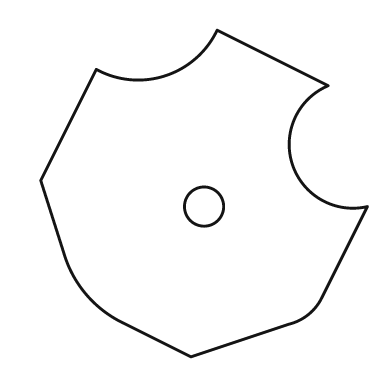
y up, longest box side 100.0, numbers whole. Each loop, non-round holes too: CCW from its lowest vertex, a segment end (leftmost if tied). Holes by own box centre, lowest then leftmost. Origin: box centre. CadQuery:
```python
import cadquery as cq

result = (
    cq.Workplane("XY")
    .moveTo(-4.0, -50.0)
    .lineTo(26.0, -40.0)
    .threePointArc((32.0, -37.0), (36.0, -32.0))
    .lineTo(50.0, -4.0)
    .threePointArc((27.0, 9.0), (38.0, 33.0))
    .lineTo(4.0, 50.0)
    .threePointArc((-12.0, 36.0), (-33.0, 38.0))
    .lineTo(-50.0, 4.0)
    .lineTo(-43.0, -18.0)
    .threePointArc((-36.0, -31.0), (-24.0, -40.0))
    .close()
    .moveTo(0.0, -4.0)
    .circle(6.0)
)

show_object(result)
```